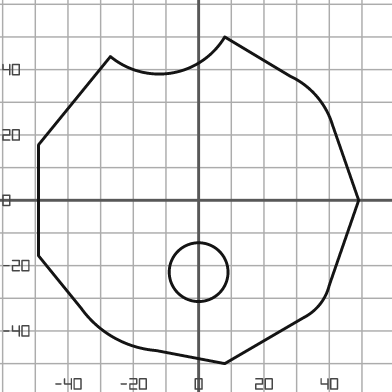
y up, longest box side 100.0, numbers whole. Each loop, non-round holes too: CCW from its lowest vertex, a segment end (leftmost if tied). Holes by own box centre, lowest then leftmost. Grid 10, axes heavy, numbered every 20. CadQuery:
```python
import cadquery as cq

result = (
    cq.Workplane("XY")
    .moveTo(8.0, -50.0)
    .lineTo(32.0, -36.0)
    .threePointArc((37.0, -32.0), (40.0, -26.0))
    .lineTo(49.0, 0.0)
    .lineTo(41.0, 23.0)
    .threePointArc((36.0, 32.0), (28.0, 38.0))
    .lineTo(8.0, 50.0)
    .threePointArc((-8.0, 39.0), (-27.0, 44.0))
    .lineTo(-49.0, 17.0)
    .lineTo(-49.0, -17.0)
    .lineTo(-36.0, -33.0)
    .threePointArc((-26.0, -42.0), (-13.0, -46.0))
    .close()
    .moveTo(0.0, -22.0)
    .circle(9.0)
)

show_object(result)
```